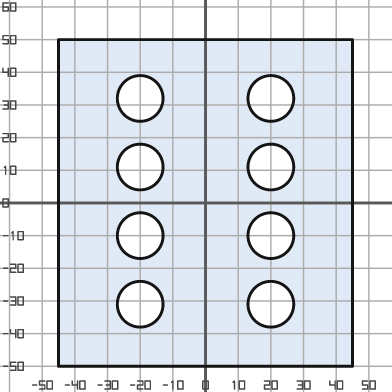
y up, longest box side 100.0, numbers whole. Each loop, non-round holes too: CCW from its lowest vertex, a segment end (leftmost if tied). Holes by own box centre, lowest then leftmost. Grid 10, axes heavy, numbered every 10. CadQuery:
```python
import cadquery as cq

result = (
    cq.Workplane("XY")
    .moveTo(-45.0, -50.0)
    .lineTo(45.0, -50.0)
    .lineTo(45.0, 50.0)
    .lineTo(-45.0, 50.0)
    .close()
    .moveTo(-20.0, -31.0)
    .circle(7.0)
    .moveTo(20.0, -31.0)
    .circle(7.0)
    .moveTo(-20.0, -10.0)
    .circle(7.0)
    .moveTo(20.0, -10.0)
    .circle(7.0)
    .moveTo(-20.0, 11.0)
    .circle(7.0)
    .moveTo(20.0, 11.0)
    .circle(7.0)
    .moveTo(-20.0, 32.0)
    .circle(7.0)
    .moveTo(20.0, 32.0)
    .circle(7.0)
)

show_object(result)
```